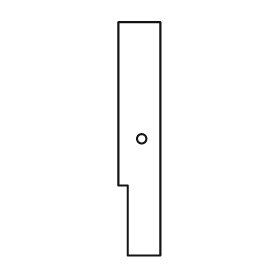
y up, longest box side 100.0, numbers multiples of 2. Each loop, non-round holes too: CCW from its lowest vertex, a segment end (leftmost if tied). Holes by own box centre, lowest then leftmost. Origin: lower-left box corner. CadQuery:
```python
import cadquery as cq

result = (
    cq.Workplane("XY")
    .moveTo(4.0, 0.0)
    .lineTo(18.0, 0.0)
    .lineTo(18.0, 100.0)
    .lineTo(0.0, 100.0)
    .lineTo(0.0, 30.0)
    .lineTo(4.0, 30.0)
    .close()
    .moveTo(10.0, 50.0)
    .circle(2.0)
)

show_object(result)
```